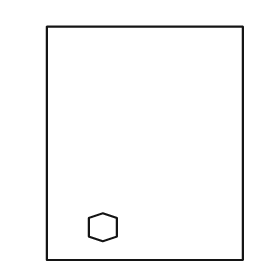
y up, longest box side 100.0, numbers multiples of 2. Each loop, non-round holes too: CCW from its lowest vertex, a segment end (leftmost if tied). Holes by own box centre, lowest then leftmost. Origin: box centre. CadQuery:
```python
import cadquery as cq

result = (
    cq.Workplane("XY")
    .moveTo(-42.0, -50.0)
    .lineTo(42.0, -50.0)
    .lineTo(42.0, 50.0)
    .lineTo(-42.0, 50.0)
    .close()
    .moveTo(-18.0, -42.0)
    .lineTo(-12.0, -40.0)
    .lineTo(-12.0, -32.0)
    .lineTo(-18.0, -30.0)
    .lineTo(-24.0, -32.0)
    .lineTo(-24.0, -40.0)
    .close()
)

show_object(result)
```